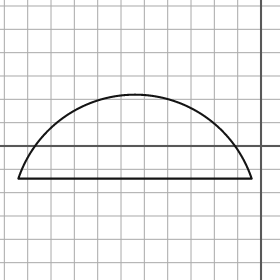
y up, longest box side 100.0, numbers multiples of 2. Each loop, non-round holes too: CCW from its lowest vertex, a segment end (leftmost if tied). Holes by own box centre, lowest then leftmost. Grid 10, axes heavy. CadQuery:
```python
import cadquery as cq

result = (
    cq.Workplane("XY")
    .moveTo(-104.0, -14.0)
    .lineTo(-4.0, -14.0)
    .threePointArc((-54.0, 22.0), (-104.0, -14.0))
    .close()
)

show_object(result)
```